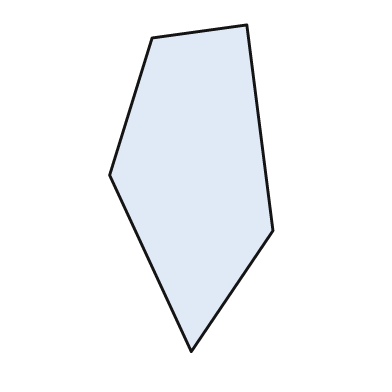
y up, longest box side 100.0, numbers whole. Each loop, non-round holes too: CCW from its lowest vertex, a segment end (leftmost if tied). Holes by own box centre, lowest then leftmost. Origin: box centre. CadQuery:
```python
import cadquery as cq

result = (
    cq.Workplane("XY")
    .moveTo(0.0, -50.0)
    .lineTo(25.0, -13.0)
    .lineTo(17.0, 50.0)
    .lineTo(-12.0, 46.0)
    .lineTo(-25.0, 4.0)
    .close()
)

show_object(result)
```